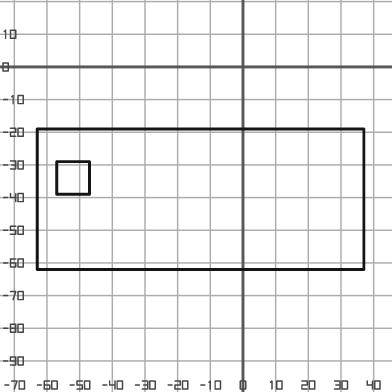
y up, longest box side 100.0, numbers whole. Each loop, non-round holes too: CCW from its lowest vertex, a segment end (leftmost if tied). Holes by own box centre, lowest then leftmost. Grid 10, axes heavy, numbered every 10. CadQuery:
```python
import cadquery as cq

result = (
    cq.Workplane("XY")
    .moveTo(-63.0, -62.0)
    .lineTo(37.0, -62.0)
    .lineTo(37.0, -19.0)
    .lineTo(-63.0, -19.0)
    .close()
    .moveTo(-57.0, -39.0)
    .lineTo(-47.0, -39.0)
    .lineTo(-47.0, -29.0)
    .lineTo(-57.0, -29.0)
    .close()
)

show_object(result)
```